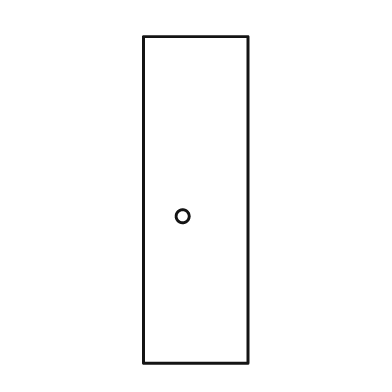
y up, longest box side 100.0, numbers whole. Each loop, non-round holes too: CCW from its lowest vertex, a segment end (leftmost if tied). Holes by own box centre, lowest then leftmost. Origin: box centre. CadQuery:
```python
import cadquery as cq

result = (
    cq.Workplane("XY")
    .moveTo(-16.0, -50.0)
    .lineTo(16.0, -50.0)
    .lineTo(16.0, 50.0)
    .lineTo(-16.0, 50.0)
    .close()
    .moveTo(-4.0, -5.0)
    .circle(2.0)
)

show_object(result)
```